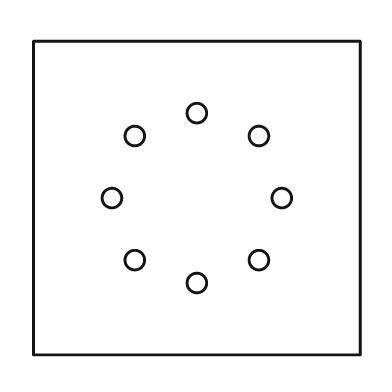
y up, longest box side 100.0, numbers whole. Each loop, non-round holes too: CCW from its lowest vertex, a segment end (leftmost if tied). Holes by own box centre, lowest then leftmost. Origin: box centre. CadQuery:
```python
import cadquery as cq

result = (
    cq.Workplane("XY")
    .moveTo(-50.0, -48.0)
    .lineTo(50.0, -48.0)
    .lineTo(50.0, 48.0)
    .lineTo(-50.0, 48.0)
    .close()
    .moveTo(0.0, -26.0)
    .circle(3.0)
    .moveTo(-19.0, -19.0)
    .circle(3.0)
    .moveTo(19.0, -19.0)
    .circle(3.0)
    .moveTo(-26.0, 0.0)
    .circle(3.0)
    .moveTo(26.0, 0.0)
    .circle(3.0)
    .moveTo(-19.0, 19.0)
    .circle(3.0)
    .moveTo(19.0, 19.0)
    .circle(3.0)
    .moveTo(0.0, 26.0)
    .circle(3.0)
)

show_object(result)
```